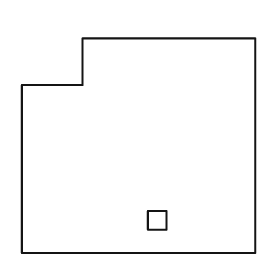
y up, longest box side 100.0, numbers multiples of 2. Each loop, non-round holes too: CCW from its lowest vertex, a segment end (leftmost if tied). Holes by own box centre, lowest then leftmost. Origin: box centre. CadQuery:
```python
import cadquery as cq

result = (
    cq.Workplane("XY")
    .moveTo(-50.0, -46.0)
    .lineTo(50.0, -46.0)
    .lineTo(50.0, 46.0)
    .lineTo(-24.0, 46.0)
    .lineTo(-24.0, 26.0)
    .lineTo(-50.0, 26.0)
    .close()
    .moveTo(4.0, -36.0)
    .lineTo(12.0, -36.0)
    .lineTo(12.0, -28.0)
    .lineTo(4.0, -28.0)
    .close()
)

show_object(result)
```